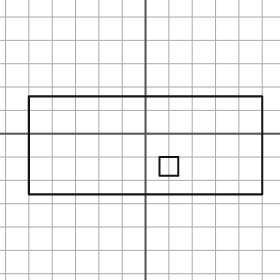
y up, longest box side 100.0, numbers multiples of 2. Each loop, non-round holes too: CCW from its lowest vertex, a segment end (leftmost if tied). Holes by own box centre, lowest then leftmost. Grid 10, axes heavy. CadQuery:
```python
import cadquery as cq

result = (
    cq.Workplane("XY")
    .moveTo(-50.0, -26.0)
    .lineTo(50.0, -26.0)
    .lineTo(50.0, 16.0)
    .lineTo(-50.0, 16.0)
    .close()
    .moveTo(6.0, -18.0)
    .lineTo(14.0, -18.0)
    .lineTo(14.0, -10.0)
    .lineTo(6.0, -10.0)
    .close()
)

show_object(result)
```